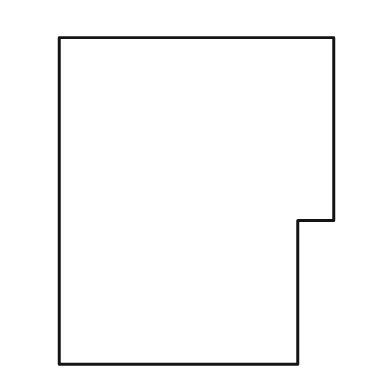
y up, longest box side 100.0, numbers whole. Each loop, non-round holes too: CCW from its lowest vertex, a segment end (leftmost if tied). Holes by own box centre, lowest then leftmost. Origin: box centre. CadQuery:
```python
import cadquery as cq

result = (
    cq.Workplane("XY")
    .moveTo(-42.0, -50.0)
    .lineTo(31.0, -50.0)
    .lineTo(31.0, -6.0)
    .lineTo(42.0, -6.0)
    .lineTo(42.0, 50.0)
    .lineTo(-42.0, 50.0)
    .close()
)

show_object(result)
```